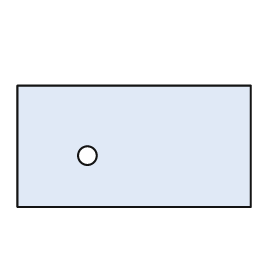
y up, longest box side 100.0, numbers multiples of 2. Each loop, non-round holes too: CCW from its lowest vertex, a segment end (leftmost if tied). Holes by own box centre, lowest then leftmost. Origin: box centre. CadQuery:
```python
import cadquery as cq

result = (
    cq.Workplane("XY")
    .moveTo(-50.0, -26.0)
    .lineTo(50.0, -26.0)
    .lineTo(50.0, 26.0)
    .lineTo(-50.0, 26.0)
    .close()
    .moveTo(-20.0, -4.0)
    .circle(4.0)
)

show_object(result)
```